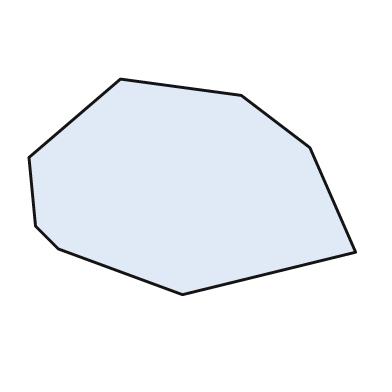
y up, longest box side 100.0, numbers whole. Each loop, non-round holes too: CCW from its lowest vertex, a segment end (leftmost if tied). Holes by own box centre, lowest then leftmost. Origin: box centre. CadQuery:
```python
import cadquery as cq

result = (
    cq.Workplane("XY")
    .moveTo(-3.0, -33.0)
    .lineTo(50.0, -20.0)
    .lineTo(36.0, 12.0)
    .lineTo(15.0, 28.0)
    .lineTo(-22.0, 33.0)
    .lineTo(-50.0, 9.0)
    .lineTo(-48.0, -12.0)
    .lineTo(-41.0, -19.0)
    .close()
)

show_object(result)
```